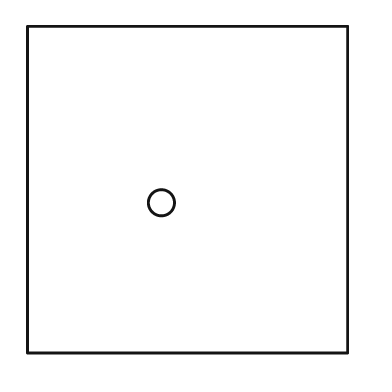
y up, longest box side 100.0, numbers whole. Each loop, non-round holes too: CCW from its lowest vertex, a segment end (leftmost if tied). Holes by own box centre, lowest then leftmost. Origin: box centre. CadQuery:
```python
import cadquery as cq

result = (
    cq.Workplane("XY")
    .moveTo(-49.0, -50.0)
    .lineTo(49.0, -50.0)
    .lineTo(49.0, 50.0)
    .lineTo(-49.0, 50.0)
    .close()
    .moveTo(-8.0, -4.0)
    .circle(4.0)
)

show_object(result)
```